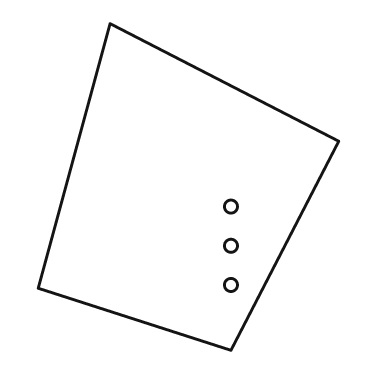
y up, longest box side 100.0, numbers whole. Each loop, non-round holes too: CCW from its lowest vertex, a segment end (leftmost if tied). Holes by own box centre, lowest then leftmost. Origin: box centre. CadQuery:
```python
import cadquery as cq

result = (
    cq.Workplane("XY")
    .moveTo(13.0, -50.0)
    .lineTo(46.0, 14.0)
    .lineTo(-24.0, 50.0)
    .lineTo(-46.0, -31.0)
    .close()
    .moveTo(13.0, -30.0)
    .circle(2.0)
    .moveTo(13.0, -18.0)
    .circle(2.0)
    .moveTo(13.0, -6.0)
    .circle(2.0)
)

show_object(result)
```